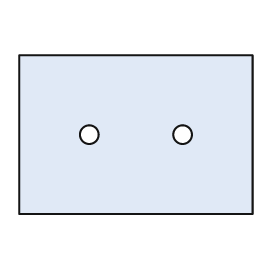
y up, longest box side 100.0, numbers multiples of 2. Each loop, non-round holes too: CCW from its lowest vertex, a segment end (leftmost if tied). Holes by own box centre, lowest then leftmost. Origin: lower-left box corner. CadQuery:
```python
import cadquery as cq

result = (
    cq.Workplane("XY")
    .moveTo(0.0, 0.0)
    .lineTo(100.0, 0.0)
    .lineTo(100.0, 68.0)
    .lineTo(0.0, 68.0)
    .close()
    .moveTo(30.0, 34.0)
    .circle(4.0)
    .moveTo(70.0, 34.0)
    .circle(4.0)
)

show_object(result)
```